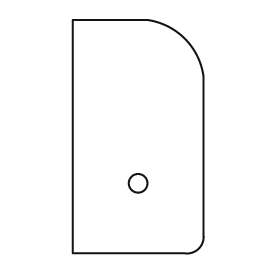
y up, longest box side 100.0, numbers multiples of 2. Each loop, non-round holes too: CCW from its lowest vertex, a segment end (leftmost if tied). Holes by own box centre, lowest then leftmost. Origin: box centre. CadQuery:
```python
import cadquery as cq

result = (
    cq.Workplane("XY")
    .moveTo(-28.0, -50.0)
    .lineTo(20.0, -50.0)
    .threePointArc((26.0, -48.0), (28.0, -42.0))
    .lineTo(28.0, 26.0)
    .threePointArc((20.0, 42.0), (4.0, 50.0))
    .lineTo(-28.0, 50.0)
    .close()
    .moveTo(0.0, -20.0)
    .circle(4.0)
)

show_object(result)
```